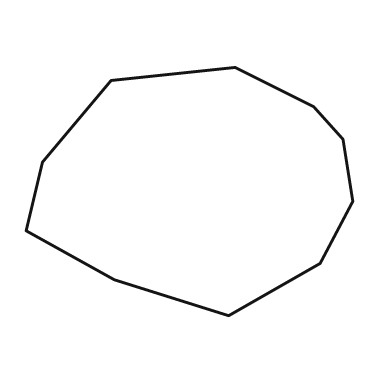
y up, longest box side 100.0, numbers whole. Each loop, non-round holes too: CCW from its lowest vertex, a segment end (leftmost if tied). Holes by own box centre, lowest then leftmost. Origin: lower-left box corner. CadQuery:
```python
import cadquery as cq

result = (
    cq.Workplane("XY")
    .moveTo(62.0, 0.0)
    .lineTo(90.0, 16.0)
    .lineTo(100.0, 35.0)
    .lineTo(97.0, 54.0)
    .lineTo(88.0, 64.0)
    .lineTo(64.0, 76.0)
    .lineTo(26.0, 72.0)
    .lineTo(5.0, 47.0)
    .lineTo(0.0, 26.0)
    .lineTo(27.0, 11.0)
    .close()
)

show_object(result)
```